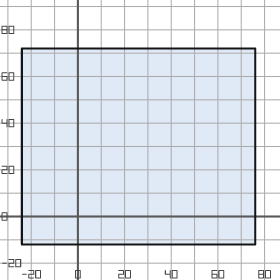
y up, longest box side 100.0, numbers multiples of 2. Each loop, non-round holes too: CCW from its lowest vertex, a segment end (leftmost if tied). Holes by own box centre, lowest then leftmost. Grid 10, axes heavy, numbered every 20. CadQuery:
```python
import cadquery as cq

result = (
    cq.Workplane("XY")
    .moveTo(-24.0, -12.0)
    .lineTo(76.0, -12.0)
    .lineTo(76.0, 72.0)
    .lineTo(-24.0, 72.0)
    .close()
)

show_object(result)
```